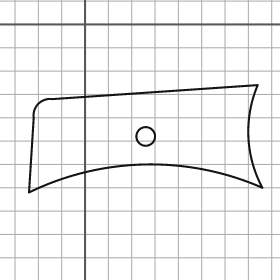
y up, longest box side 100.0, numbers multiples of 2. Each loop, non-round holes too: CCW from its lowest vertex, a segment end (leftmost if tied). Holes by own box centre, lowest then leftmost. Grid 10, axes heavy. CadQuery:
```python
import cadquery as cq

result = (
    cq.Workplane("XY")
    .moveTo(-24.0, -72.0)
    .threePointArc((26.0, -60.0), (76.0, -70.0))
    .threePointArc((70.0, -48.0), (74.0, -26.0))
    .lineTo(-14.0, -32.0)
    .threePointArc((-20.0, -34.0), (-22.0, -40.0))
    .close()
    .moveTo(26.0, -48.0)
    .circle(4.0)
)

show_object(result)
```